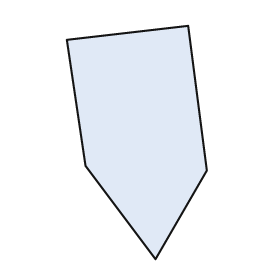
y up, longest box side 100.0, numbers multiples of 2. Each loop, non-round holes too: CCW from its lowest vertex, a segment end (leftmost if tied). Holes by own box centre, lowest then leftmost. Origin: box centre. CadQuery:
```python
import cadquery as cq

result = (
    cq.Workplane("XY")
    .moveTo(8.0, -50.0)
    .lineTo(30.0, -12.0)
    .lineTo(22.0, 50.0)
    .lineTo(-30.0, 44.0)
    .lineTo(-22.0, -10.0)
    .close()
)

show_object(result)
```